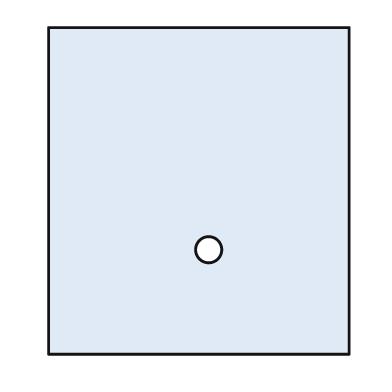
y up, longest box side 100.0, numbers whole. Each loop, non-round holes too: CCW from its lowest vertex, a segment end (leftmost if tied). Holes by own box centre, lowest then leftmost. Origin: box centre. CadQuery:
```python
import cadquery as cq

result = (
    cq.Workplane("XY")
    .moveTo(-46.0, -50.0)
    .lineTo(46.0, -50.0)
    .lineTo(46.0, 50.0)
    .lineTo(-46.0, 50.0)
    .close()
    .moveTo(3.0, -18.0)
    .circle(4.0)
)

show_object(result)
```